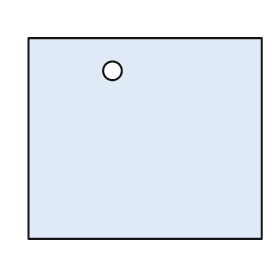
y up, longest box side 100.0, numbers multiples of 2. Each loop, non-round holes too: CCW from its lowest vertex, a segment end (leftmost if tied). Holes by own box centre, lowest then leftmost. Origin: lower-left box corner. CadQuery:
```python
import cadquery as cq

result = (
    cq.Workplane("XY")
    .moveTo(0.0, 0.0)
    .lineTo(100.0, 0.0)
    .lineTo(100.0, 86.0)
    .lineTo(0.0, 86.0)
    .close()
    .moveTo(36.0, 72.0)
    .circle(4.0)
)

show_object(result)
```